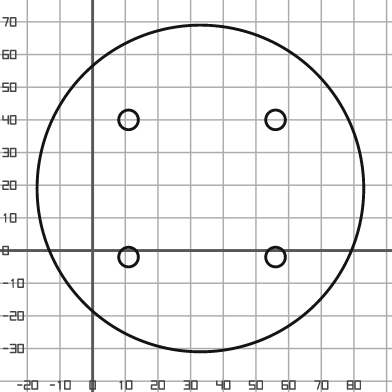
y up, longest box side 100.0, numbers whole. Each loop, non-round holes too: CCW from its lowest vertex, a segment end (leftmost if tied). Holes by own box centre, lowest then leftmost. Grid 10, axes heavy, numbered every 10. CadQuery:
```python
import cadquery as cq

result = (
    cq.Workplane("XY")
    .moveTo(33.0, 19.0)
    .circle(50.0)
    .moveTo(11.0, -2.0)
    .circle(3.0)
    .moveTo(56.0, -2.0)
    .circle(3.0)
    .moveTo(11.0, 40.0)
    .circle(3.0)
    .moveTo(56.0, 40.0)
    .circle(3.0)
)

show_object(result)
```